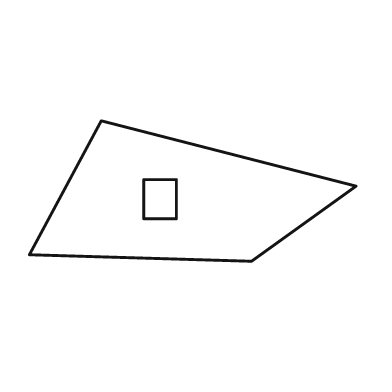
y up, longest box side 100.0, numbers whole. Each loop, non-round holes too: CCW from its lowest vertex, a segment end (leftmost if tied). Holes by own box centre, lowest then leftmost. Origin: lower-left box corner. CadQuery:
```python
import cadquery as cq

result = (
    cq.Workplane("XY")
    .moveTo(68.0, 0.0)
    .lineTo(100.0, 23.0)
    .lineTo(22.0, 43.0)
    .lineTo(0.0, 2.0)
    .close()
    .moveTo(35.0, 13.0)
    .lineTo(45.0, 13.0)
    .lineTo(45.0, 25.0)
    .lineTo(35.0, 25.0)
    .close()
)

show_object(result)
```